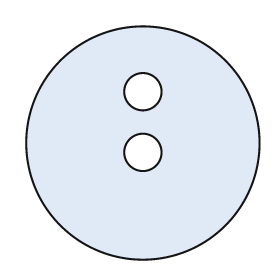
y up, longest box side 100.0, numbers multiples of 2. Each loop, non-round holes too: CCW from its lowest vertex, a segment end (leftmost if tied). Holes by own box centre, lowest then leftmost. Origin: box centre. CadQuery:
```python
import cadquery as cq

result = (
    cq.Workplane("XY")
    .moveTo(0.0, 0.0)
    .circle(50.0)
    .moveTo(0.0, -4.0)
    .circle(8.0)
    .moveTo(0.0, 22.0)
    .circle(8.0)
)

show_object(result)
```